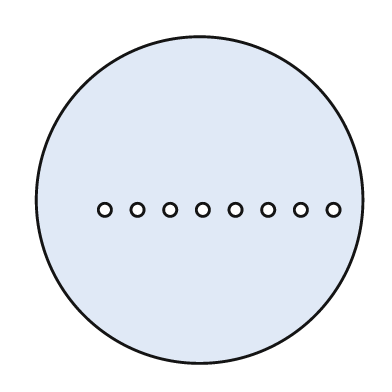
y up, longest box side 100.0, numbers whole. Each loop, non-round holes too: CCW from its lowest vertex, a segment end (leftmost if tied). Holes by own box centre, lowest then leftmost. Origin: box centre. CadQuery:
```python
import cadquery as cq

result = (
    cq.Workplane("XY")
    .moveTo(0.0, 0.0)
    .circle(50.0)
    .moveTo(-29.0, -3.0)
    .circle(2.0)
    .moveTo(-19.0, -3.0)
    .circle(2.0)
    .moveTo(-9.0, -3.0)
    .circle(2.0)
    .moveTo(1.0, -3.0)
    .circle(2.0)
    .moveTo(11.0, -3.0)
    .circle(2.0)
    .moveTo(21.0, -3.0)
    .circle(2.0)
    .moveTo(31.0, -3.0)
    .circle(2.0)
    .moveTo(41.0, -3.0)
    .circle(2.0)
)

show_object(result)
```